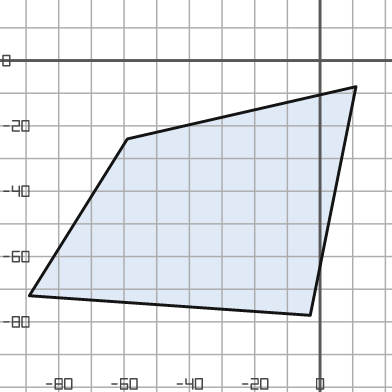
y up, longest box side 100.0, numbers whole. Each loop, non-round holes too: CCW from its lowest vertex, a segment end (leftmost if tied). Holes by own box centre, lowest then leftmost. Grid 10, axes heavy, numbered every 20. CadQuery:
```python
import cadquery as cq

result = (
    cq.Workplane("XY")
    .moveTo(-3.0, -78.0)
    .lineTo(11.0, -8.0)
    .lineTo(-59.0, -24.0)
    .lineTo(-89.0, -72.0)
    .close()
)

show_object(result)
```